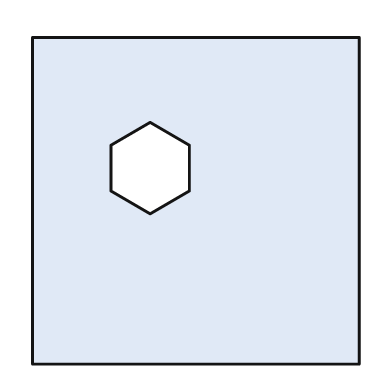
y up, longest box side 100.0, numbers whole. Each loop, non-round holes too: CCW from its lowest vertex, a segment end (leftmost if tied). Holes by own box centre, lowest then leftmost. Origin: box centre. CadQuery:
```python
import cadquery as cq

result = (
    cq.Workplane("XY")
    .moveTo(-50.0, -50.0)
    .lineTo(50.0, -50.0)
    .lineTo(50.0, 50.0)
    .lineTo(-50.0, 50.0)
    .close()
    .moveTo(-14.0, -4.0)
    .lineTo(-2.0, 3.0)
    .lineTo(-2.0, 17.0)
    .lineTo(-14.0, 24.0)
    .lineTo(-26.0, 17.0)
    .lineTo(-26.0, 3.0)
    .close()
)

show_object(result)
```